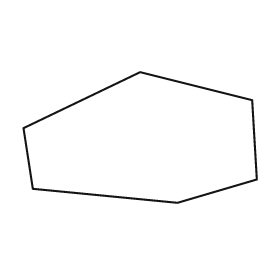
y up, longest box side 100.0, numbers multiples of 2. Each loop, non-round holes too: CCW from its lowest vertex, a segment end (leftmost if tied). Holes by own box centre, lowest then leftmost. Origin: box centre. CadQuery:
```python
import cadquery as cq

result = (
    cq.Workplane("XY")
    .moveTo(16.0, -28.0)
    .lineTo(50.0, -18.0)
    .lineTo(48.0, 16.0)
    .lineTo(0.0, 28.0)
    .lineTo(-50.0, 4.0)
    .lineTo(-46.0, -22.0)
    .close()
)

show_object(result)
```